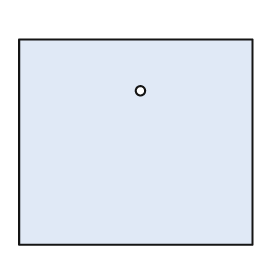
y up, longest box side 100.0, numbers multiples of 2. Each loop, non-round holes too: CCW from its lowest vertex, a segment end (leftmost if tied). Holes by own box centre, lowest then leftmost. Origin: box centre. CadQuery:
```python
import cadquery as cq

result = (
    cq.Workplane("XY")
    .moveTo(-50.0, -44.0)
    .lineTo(50.0, -44.0)
    .lineTo(50.0, 44.0)
    .lineTo(-50.0, 44.0)
    .close()
    .moveTo(2.0, 22.0)
    .circle(2.0)
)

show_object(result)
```